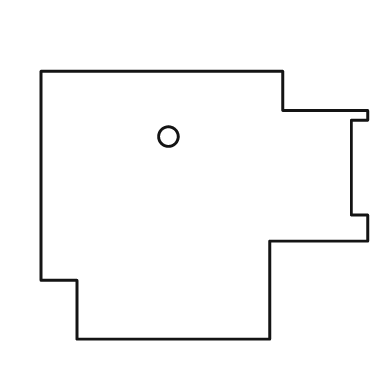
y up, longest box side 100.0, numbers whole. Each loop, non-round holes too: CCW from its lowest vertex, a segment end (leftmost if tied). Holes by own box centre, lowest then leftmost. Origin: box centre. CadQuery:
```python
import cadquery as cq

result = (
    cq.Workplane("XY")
    .moveTo(-39.0, -41.0)
    .lineTo(20.0, -41.0)
    .lineTo(20.0, -11.0)
    .lineTo(50.0, -11.0)
    .lineTo(50.0, -3.0)
    .lineTo(45.0, -3.0)
    .lineTo(45.0, 26.0)
    .lineTo(50.0, 26.0)
    .lineTo(50.0, 29.0)
    .lineTo(24.0, 29.0)
    .lineTo(24.0, 41.0)
    .lineTo(-50.0, 41.0)
    .lineTo(-50.0, -23.0)
    .lineTo(-39.0, -23.0)
    .close()
    .moveTo(-11.0, 21.0)
    .circle(3.0)
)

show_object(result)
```